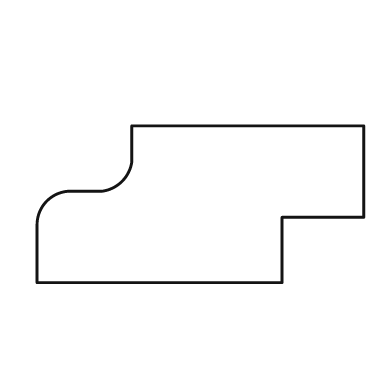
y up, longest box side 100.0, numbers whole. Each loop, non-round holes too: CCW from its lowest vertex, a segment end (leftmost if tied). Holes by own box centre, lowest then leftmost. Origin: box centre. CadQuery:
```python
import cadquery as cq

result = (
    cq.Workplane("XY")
    .moveTo(-50.0, -24.0)
    .lineTo(25.0, -24.0)
    .lineTo(25.0, -4.0)
    .lineTo(50.0, -4.0)
    .lineTo(50.0, 24.0)
    .lineTo(-21.0, 24.0)
    .lineTo(-21.0, 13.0)
    .threePointArc((-24.0, 7.0), (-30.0, 4.0))
    .lineTo(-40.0, 4.0)
    .threePointArc((-47.0, 1.0), (-50.0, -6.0))
    .close()
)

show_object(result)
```